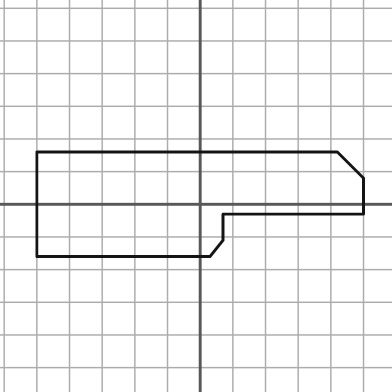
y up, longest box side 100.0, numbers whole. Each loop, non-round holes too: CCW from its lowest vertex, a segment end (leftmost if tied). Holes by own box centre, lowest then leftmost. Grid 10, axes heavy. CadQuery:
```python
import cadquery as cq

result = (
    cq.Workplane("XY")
    .moveTo(-50.0, -16.0)
    .lineTo(3.0, -16.0)
    .lineTo(7.0, -11.0)
    .lineTo(7.0, -3.0)
    .lineTo(50.0, -3.0)
    .lineTo(50.0, 8.0)
    .lineTo(42.0, 16.0)
    .lineTo(-50.0, 16.0)
    .close()
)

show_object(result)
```